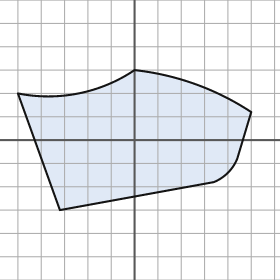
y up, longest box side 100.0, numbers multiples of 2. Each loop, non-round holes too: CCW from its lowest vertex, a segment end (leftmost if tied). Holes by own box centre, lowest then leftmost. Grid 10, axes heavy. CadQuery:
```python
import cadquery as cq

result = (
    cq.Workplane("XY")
    .moveTo(-32.0, -30.0)
    .lineTo(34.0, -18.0)
    .threePointArc((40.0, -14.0), (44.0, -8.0))
    .lineTo(50.0, 12.0)
    .threePointArc((26.0, 24.0), (0.0, 30.0))
    .threePointArc((-24.0, 20.0), (-50.0, 20.0))
    .close()
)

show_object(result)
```